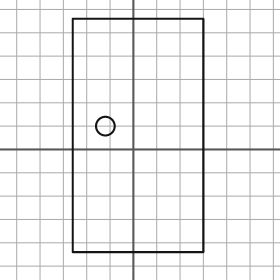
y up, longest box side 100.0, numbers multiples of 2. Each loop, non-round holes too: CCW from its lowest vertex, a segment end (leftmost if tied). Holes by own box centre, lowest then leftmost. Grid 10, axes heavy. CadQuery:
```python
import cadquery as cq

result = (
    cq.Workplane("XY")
    .moveTo(-26.0, -44.0)
    .lineTo(30.0, -44.0)
    .lineTo(30.0, 56.0)
    .lineTo(-26.0, 56.0)
    .close()
    .moveTo(-12.0, 10.0)
    .circle(4.0)
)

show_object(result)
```